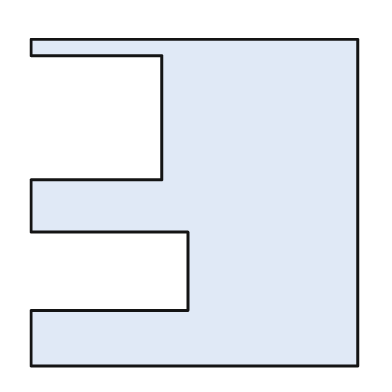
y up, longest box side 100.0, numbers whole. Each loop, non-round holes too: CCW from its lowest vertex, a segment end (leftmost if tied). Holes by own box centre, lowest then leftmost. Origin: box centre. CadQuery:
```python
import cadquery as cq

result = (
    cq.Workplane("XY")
    .moveTo(-50.0, -50.0)
    .lineTo(50.0, -50.0)
    .lineTo(50.0, 50.0)
    .lineTo(-50.0, 50.0)
    .lineTo(-50.0, 45.0)
    .lineTo(-10.0, 45.0)
    .lineTo(-10.0, 7.0)
    .lineTo(-50.0, 7.0)
    .lineTo(-50.0, -9.0)
    .lineTo(-2.0, -9.0)
    .lineTo(-2.0, -33.0)
    .lineTo(-50.0, -33.0)
    .close()
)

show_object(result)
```